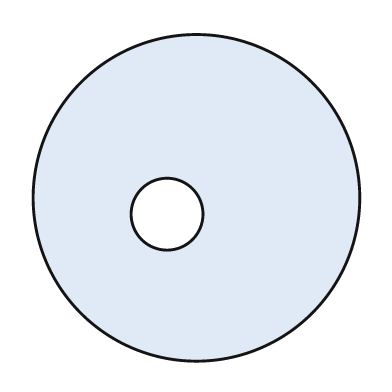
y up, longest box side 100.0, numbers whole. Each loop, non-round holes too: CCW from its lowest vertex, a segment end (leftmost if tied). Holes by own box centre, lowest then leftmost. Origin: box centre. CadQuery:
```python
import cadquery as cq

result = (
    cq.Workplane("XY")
    .moveTo(0.0, 0.0)
    .circle(50.0)
    .moveTo(-9.0, -5.0)
    .circle(11.0)
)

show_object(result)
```